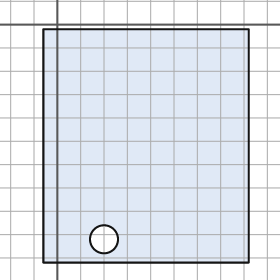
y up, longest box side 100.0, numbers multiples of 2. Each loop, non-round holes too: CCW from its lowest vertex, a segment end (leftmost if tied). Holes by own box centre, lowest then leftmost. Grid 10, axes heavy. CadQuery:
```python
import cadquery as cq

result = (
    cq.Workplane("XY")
    .moveTo(-6.0, -102.0)
    .lineTo(82.0, -102.0)
    .lineTo(82.0, -2.0)
    .lineTo(-6.0, -2.0)
    .close()
    .moveTo(20.0, -92.0)
    .circle(6.0)
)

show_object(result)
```